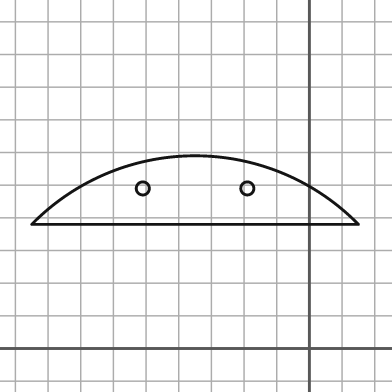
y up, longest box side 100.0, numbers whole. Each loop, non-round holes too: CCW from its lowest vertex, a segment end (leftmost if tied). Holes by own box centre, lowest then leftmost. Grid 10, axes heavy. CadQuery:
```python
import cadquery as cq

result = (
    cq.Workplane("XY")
    .moveTo(-85.0, 38.0)
    .lineTo(15.0, 38.0)
    .threePointArc((-35.0, 59.0), (-85.0, 38.0))
    .close()
    .moveTo(-51.0, 49.0)
    .circle(2.0)
    .moveTo(-19.0, 49.0)
    .circle(2.0)
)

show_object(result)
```